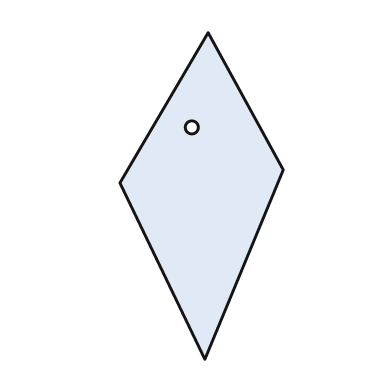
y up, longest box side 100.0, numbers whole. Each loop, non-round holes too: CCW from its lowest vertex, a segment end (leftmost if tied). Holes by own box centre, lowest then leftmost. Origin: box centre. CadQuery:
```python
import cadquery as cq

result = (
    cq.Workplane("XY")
    .moveTo(1.0, -50.0)
    .lineTo(25.0, 8.0)
    .lineTo(2.0, 50.0)
    .lineTo(-25.0, 4.0)
    .close()
    .moveTo(-3.0, 21.0)
    .circle(2.0)
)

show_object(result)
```